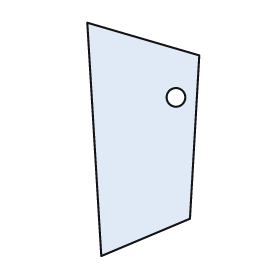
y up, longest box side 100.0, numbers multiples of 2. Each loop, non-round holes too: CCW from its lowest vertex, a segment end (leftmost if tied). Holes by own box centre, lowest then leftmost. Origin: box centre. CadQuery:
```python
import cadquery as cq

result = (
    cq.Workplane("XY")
    .moveTo(-18.0, -50.0)
    .lineTo(20.0, -34.0)
    .lineTo(24.0, 36.0)
    .lineTo(-24.0, 50.0)
    .close()
    .moveTo(14.0, 18.0)
    .circle(4.0)
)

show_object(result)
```